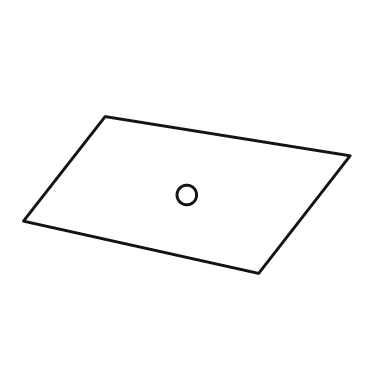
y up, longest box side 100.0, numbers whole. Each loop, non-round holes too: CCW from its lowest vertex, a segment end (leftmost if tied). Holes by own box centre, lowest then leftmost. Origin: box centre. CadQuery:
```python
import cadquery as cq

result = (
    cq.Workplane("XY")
    .moveTo(22.0, -24.0)
    .lineTo(50.0, 12.0)
    .lineTo(-25.0, 24.0)
    .lineTo(-50.0, -8.0)
    .close()
    .moveTo(0.0, 0.0)
    .circle(3.0)
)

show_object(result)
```